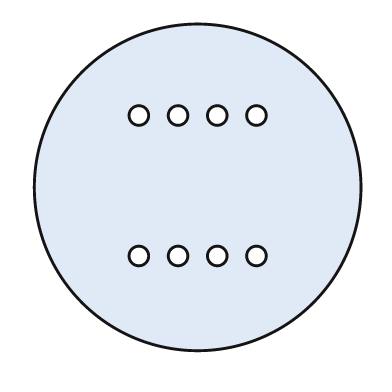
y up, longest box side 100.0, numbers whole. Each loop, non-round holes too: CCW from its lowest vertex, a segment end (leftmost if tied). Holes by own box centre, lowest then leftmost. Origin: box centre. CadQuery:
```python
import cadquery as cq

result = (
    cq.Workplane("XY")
    .moveTo(0.0, 0.0)
    .circle(50.0)
    .moveTo(-18.0, -21.0)
    .circle(3.0)
    .moveTo(-6.0, -21.0)
    .circle(3.0)
    .moveTo(6.0, -21.0)
    .circle(3.0)
    .moveTo(18.0, -21.0)
    .circle(3.0)
    .moveTo(-18.0, 22.0)
    .circle(3.0)
    .moveTo(-6.0, 22.0)
    .circle(3.0)
    .moveTo(6.0, 22.0)
    .circle(3.0)
    .moveTo(18.0, 22.0)
    .circle(3.0)
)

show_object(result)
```